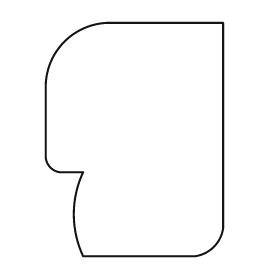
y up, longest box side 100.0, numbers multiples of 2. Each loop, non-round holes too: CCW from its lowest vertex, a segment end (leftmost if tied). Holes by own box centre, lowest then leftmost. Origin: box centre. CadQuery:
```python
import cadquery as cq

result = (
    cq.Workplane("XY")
    .moveTo(-22.0, -50.0)
    .lineTo(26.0, -50.0)
    .threePointArc((34.0, -46.0), (38.0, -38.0))
    .lineTo(38.0, 50.0)
    .lineTo(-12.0, 50.0)
    .threePointArc((-30.0, 42.0), (-38.0, 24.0))
    .lineTo(-38.0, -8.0)
    .threePointArc((-36.0, -12.0), (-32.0, -14.0))
    .lineTo(-22.0, -14.0)
    .threePointArc((-26.0, -32.0), (-22.0, -50.0))
    .close()
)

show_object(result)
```